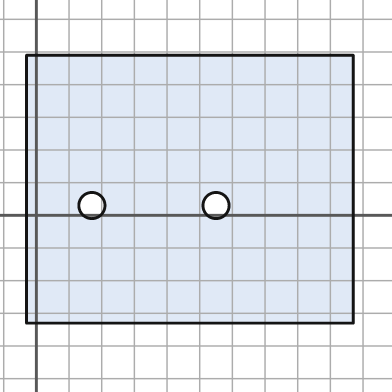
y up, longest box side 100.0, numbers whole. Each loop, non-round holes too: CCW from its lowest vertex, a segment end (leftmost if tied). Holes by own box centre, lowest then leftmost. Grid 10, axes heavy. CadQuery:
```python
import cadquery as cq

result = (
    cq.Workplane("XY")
    .moveTo(-3.0, -33.0)
    .lineTo(97.0, -33.0)
    .lineTo(97.0, 49.0)
    .lineTo(-3.0, 49.0)
    .close()
    .moveTo(17.0, 3.0)
    .circle(4.0)
    .moveTo(55.0, 3.0)
    .circle(4.0)
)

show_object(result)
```